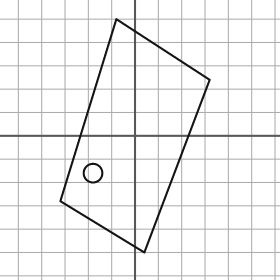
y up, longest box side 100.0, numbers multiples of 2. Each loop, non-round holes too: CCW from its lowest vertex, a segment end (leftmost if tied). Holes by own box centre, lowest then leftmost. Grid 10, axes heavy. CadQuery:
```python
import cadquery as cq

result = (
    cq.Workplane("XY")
    .moveTo(4.0, -50.0)
    .lineTo(32.0, 24.0)
    .lineTo(-8.0, 50.0)
    .lineTo(-32.0, -28.0)
    .close()
    .moveTo(-18.0, -16.0)
    .circle(4.0)
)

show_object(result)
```